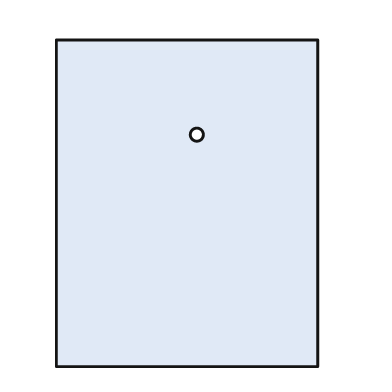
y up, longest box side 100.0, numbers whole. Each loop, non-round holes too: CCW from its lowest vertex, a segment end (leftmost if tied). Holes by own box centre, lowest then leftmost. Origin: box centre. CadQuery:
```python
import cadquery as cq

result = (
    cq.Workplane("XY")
    .moveTo(-40.0, -50.0)
    .lineTo(40.0, -50.0)
    .lineTo(40.0, 50.0)
    .lineTo(-40.0, 50.0)
    .close()
    .moveTo(3.0, 21.0)
    .circle(2.0)
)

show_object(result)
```